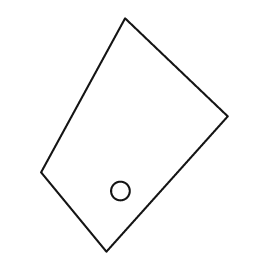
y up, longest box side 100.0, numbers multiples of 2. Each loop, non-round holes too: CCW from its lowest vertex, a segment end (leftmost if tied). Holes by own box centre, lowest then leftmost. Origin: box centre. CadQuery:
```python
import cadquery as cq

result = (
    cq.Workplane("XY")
    .moveTo(-12.0, -50.0)
    .lineTo(40.0, 8.0)
    .lineTo(-4.0, 50.0)
    .lineTo(-40.0, -16.0)
    .close()
    .moveTo(-6.0, -24.0)
    .circle(4.0)
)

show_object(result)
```